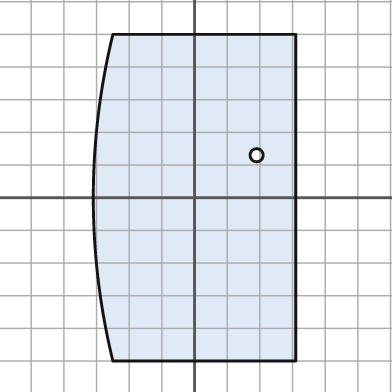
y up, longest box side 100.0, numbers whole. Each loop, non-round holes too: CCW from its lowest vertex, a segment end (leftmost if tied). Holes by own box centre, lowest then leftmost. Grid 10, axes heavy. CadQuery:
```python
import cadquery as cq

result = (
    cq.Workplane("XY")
    .moveTo(-25.0, -50.0)
    .lineTo(31.0, -50.0)
    .lineTo(31.0, 50.0)
    .lineTo(-25.0, 50.0)
    .threePointArc((-31.0, 0.0), (-25.0, -50.0))
    .close()
    .moveTo(19.0, 13.0)
    .circle(2.0)
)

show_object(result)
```